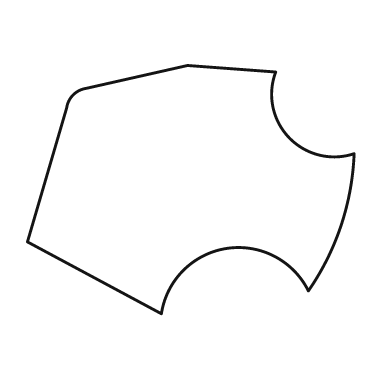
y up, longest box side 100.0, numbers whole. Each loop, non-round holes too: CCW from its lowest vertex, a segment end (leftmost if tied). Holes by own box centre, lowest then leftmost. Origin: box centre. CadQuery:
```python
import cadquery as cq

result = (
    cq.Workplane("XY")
    .moveTo(-9.0, -38.0)
    .threePointArc((11.0, -18.0), (36.0, -31.0))
    .threePointArc((46.0, -11.0), (50.0, 11.0))
    .threePointArc((30.0, 16.0), (26.0, 36.0))
    .lineTo(-1.0, 38.0)
    .lineTo(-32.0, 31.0)
    .threePointArc((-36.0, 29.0), (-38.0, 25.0))
    .lineTo(-50.0, -16.0)
    .close()
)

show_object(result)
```